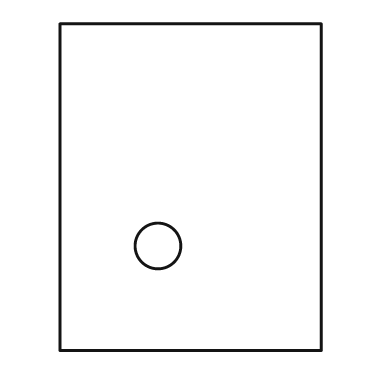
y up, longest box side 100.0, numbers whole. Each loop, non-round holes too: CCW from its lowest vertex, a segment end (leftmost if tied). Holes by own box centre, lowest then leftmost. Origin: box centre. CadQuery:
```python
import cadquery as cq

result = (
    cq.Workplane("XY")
    .moveTo(-40.0, -50.0)
    .lineTo(40.0, -50.0)
    .lineTo(40.0, 50.0)
    .lineTo(-40.0, 50.0)
    .close()
    .moveTo(-10.0, -18.0)
    .circle(7.0)
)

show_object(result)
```